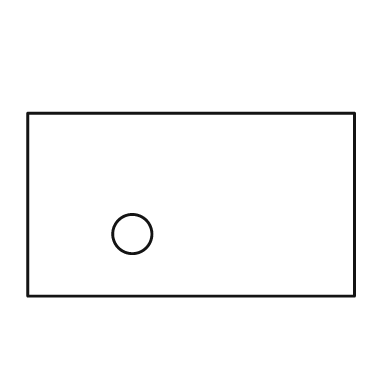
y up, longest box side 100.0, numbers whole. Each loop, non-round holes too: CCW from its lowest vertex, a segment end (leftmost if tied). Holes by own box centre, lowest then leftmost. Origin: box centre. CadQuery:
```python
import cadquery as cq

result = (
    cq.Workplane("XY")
    .moveTo(-50.0, -28.0)
    .lineTo(50.0, -28.0)
    .lineTo(50.0, 28.0)
    .lineTo(-50.0, 28.0)
    .close()
    .moveTo(-18.0, -9.0)
    .circle(6.0)
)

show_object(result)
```